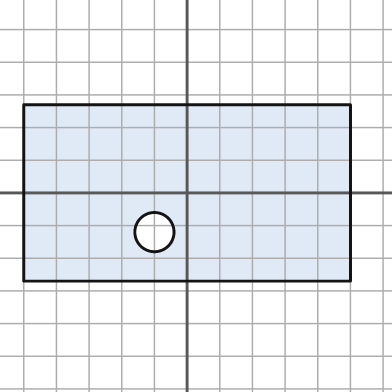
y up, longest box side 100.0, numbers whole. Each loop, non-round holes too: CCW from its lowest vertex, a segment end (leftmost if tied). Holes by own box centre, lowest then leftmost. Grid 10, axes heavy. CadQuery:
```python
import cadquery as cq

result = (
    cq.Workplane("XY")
    .moveTo(-50.0, -27.0)
    .lineTo(50.0, -27.0)
    .lineTo(50.0, 27.0)
    .lineTo(-50.0, 27.0)
    .close()
    .moveTo(-10.0, -12.0)
    .circle(6.0)
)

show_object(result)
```